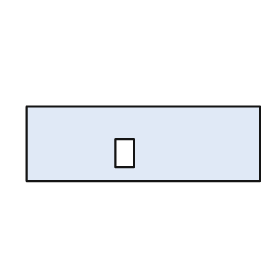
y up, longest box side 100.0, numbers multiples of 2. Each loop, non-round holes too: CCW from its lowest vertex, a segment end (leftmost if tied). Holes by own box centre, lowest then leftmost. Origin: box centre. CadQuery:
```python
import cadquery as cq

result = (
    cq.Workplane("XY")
    .moveTo(-50.0, -16.0)
    .lineTo(50.0, -16.0)
    .lineTo(50.0, 16.0)
    .lineTo(-50.0, 16.0)
    .close()
    .moveTo(-12.0, -10.0)
    .lineTo(-4.0, -10.0)
    .lineTo(-4.0, 2.0)
    .lineTo(-12.0, 2.0)
    .close()
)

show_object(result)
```